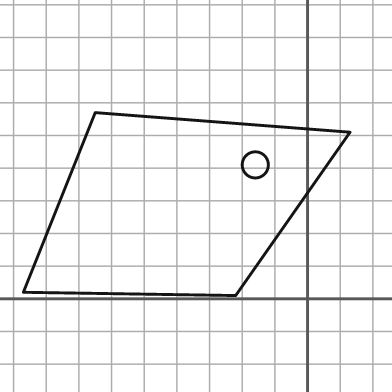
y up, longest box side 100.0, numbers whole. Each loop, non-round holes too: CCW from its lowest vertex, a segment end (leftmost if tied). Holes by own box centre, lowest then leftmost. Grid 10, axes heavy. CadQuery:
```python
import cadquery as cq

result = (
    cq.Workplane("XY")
    .moveTo(-22.0, 1.0)
    .lineTo(13.0, 51.0)
    .lineTo(-65.0, 57.0)
    .lineTo(-87.0, 2.0)
    .close()
    .moveTo(-16.0, 41.0)
    .circle(4.0)
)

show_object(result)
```